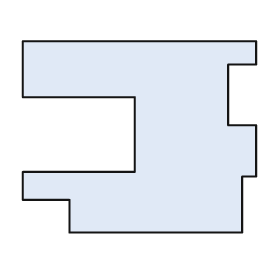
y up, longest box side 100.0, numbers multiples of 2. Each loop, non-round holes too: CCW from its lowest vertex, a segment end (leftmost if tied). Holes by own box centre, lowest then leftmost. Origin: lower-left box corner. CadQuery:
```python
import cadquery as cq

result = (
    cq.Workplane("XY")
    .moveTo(20.0, 0.0)
    .lineTo(94.0, 0.0)
    .lineTo(94.0, 24.0)
    .lineTo(100.0, 24.0)
    .lineTo(100.0, 46.0)
    .lineTo(88.0, 46.0)
    .lineTo(88.0, 72.0)
    .lineTo(100.0, 72.0)
    .lineTo(100.0, 82.0)
    .lineTo(0.0, 82.0)
    .lineTo(0.0, 58.0)
    .lineTo(48.0, 58.0)
    .lineTo(48.0, 26.0)
    .lineTo(0.0, 26.0)
    .lineTo(0.0, 14.0)
    .lineTo(20.0, 14.0)
    .close()
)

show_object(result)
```